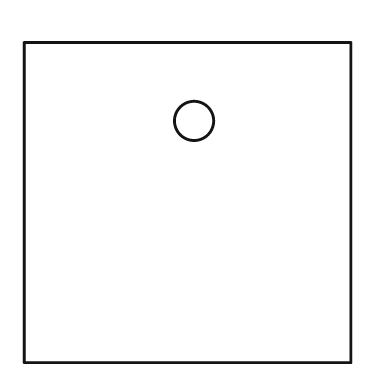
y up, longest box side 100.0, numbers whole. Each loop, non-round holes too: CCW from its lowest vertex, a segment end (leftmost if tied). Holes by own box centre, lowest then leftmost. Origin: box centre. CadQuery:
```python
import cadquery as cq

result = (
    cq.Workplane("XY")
    .moveTo(-50.0, -49.0)
    .lineTo(50.0, -49.0)
    .lineTo(50.0, 49.0)
    .lineTo(-50.0, 49.0)
    .close()
    .moveTo(2.0, 25.0)
    .circle(6.0)
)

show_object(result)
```